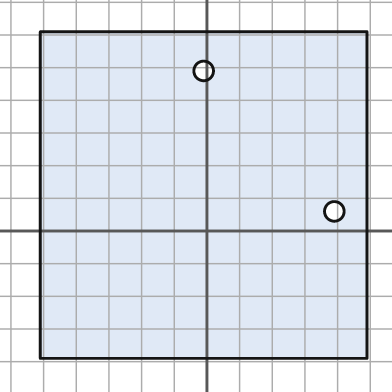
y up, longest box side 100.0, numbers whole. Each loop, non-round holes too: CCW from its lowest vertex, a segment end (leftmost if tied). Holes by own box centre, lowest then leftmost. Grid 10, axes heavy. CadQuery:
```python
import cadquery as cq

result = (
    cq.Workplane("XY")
    .moveTo(-51.0, -39.0)
    .lineTo(49.0, -39.0)
    .lineTo(49.0, 61.0)
    .lineTo(-51.0, 61.0)
    .close()
    .moveTo(39.0, 6.0)
    .circle(3.0)
    .moveTo(-1.0, 49.0)
    .circle(3.0)
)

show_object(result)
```